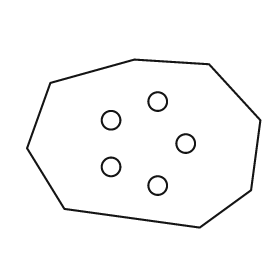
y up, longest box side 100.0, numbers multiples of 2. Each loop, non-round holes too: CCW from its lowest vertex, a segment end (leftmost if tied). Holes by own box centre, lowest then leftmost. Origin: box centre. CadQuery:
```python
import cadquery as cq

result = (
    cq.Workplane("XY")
    .moveTo(24.0, -36.0)
    .lineTo(46.0, -20.0)
    .lineTo(50.0, 10.0)
    .lineTo(28.0, 34.0)
    .lineTo(-4.0, 36.0)
    .lineTo(-40.0, 26.0)
    .lineTo(-50.0, -2.0)
    .lineTo(-34.0, -28.0)
    .close()
    .moveTo(6.0, -18.0)
    .circle(4.0)
    .moveTo(-14.0, -10.0)
    .circle(4.0)
    .moveTo(18.0, 0.0)
    .circle(4.0)
    .moveTo(-14.0, 10.0)
    .circle(4.0)
    .moveTo(6.0, 18.0)
    .circle(4.0)
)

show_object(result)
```